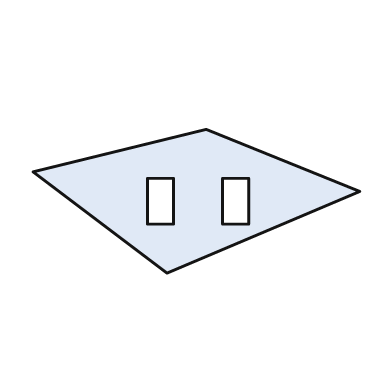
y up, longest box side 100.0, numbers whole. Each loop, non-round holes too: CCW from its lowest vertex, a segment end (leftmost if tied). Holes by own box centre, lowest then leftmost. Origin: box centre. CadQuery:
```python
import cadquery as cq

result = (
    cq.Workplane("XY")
    .moveTo(-9.0, -22.0)
    .lineTo(50.0, 3.0)
    .lineTo(3.0, 22.0)
    .lineTo(-50.0, 9.0)
    .close()
    .moveTo(-15.0, -7.0)
    .lineTo(-7.0, -7.0)
    .lineTo(-7.0, 7.0)
    .lineTo(-15.0, 7.0)
    .close()
    .moveTo(8.0, -7.0)
    .lineTo(16.0, -7.0)
    .lineTo(16.0, 7.0)
    .lineTo(8.0, 7.0)
    .close()
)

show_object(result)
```